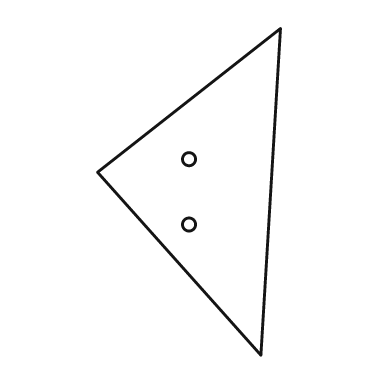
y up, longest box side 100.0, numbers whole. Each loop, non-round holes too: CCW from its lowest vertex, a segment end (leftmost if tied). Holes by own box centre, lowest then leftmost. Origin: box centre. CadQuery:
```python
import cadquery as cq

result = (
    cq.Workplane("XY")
    .moveTo(22.0, -50.0)
    .lineTo(28.0, 50.0)
    .lineTo(-28.0, 6.0)
    .close()
    .moveTo(0.0, -10.0)
    .circle(2.0)
    .moveTo(0.0, 10.0)
    .circle(2.0)
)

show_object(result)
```